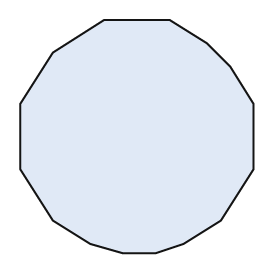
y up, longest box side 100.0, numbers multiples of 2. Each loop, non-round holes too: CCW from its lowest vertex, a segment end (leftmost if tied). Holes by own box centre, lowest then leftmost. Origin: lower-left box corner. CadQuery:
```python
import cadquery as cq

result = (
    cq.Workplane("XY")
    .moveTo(44.0, 0.0)
    .lineTo(58.0, 0.0)
    .lineTo(70.0, 4.0)
    .lineTo(86.0, 14.0)
    .lineTo(100.0, 36.0)
    .lineTo(100.0, 64.0)
    .lineTo(90.0, 80.0)
    .lineTo(80.0, 90.0)
    .lineTo(64.0, 100.0)
    .lineTo(36.0, 100.0)
    .lineTo(14.0, 86.0)
    .lineTo(0.0, 64.0)
    .lineTo(0.0, 36.0)
    .lineTo(14.0, 14.0)
    .lineTo(30.0, 4.0)
    .close()
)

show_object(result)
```